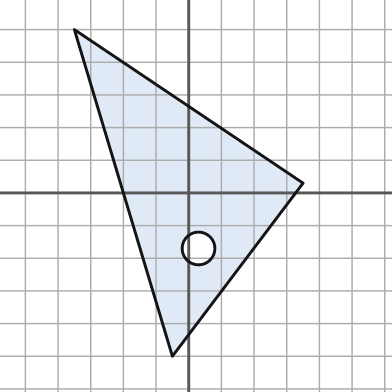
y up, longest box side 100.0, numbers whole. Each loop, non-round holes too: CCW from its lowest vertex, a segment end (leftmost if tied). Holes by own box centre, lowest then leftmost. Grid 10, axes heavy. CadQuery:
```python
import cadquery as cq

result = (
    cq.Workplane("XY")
    .moveTo(-5.0, -50.0)
    .lineTo(35.0, 3.0)
    .lineTo(-35.0, 50.0)
    .close()
    .moveTo(3.0, -17.0)
    .circle(5.0)
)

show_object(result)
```